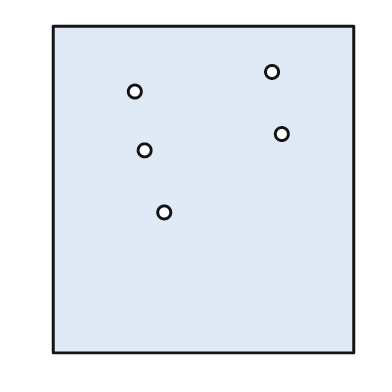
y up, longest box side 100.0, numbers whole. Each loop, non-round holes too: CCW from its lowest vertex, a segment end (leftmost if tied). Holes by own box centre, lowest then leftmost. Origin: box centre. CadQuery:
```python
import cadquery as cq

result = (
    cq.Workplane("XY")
    .moveTo(-46.0, -50.0)
    .lineTo(46.0, -50.0)
    .lineTo(46.0, 50.0)
    .lineTo(-46.0, 50.0)
    .close()
    .moveTo(-12.0, -7.0)
    .circle(2.0)
    .moveTo(-18.0, 12.0)
    .circle(2.0)
    .moveTo(24.0, 17.0)
    .circle(2.0)
    .moveTo(-21.0, 30.0)
    .circle(2.0)
    .moveTo(21.0, 36.0)
    .circle(2.0)
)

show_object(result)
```